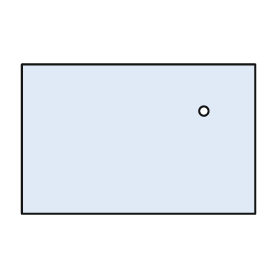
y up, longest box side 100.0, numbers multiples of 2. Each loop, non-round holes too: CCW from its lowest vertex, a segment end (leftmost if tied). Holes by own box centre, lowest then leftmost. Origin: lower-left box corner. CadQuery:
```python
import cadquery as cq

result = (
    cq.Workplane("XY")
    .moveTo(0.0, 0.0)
    .lineTo(100.0, 0.0)
    .lineTo(100.0, 64.0)
    .lineTo(0.0, 64.0)
    .close()
    .moveTo(78.0, 44.0)
    .circle(2.0)
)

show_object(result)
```